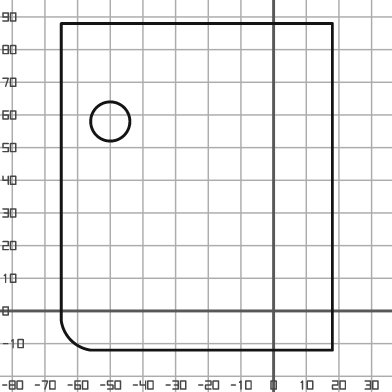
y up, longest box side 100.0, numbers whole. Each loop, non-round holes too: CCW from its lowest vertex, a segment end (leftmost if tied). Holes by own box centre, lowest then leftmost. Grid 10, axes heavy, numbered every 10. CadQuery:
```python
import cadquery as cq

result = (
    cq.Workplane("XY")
    .moveTo(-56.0, -12.0)
    .lineTo(18.0, -12.0)
    .lineTo(18.0, 88.0)
    .lineTo(-65.0, 88.0)
    .lineTo(-65.0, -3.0)
    .threePointArc((-62.0, -9.0), (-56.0, -12.0))
    .close()
    .moveTo(-50.0, 58.0)
    .circle(6.0)
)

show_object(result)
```